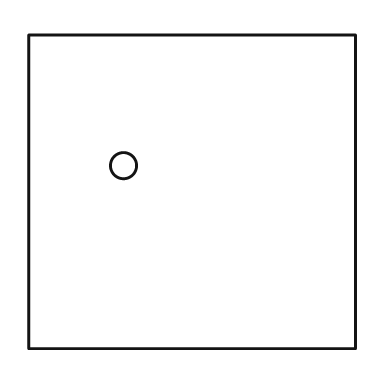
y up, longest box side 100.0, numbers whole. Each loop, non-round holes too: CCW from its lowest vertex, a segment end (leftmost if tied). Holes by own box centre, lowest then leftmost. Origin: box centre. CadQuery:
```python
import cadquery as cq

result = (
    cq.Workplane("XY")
    .moveTo(-50.0, -48.0)
    .lineTo(50.0, -48.0)
    .lineTo(50.0, 48.0)
    .lineTo(-50.0, 48.0)
    .close()
    .moveTo(-21.0, 8.0)
    .circle(4.0)
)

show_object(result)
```